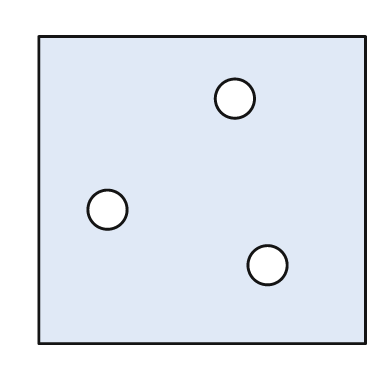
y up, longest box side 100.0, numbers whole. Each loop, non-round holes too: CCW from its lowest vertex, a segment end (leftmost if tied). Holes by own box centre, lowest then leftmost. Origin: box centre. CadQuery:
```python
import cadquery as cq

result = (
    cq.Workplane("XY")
    .moveTo(-50.0, -47.0)
    .lineTo(50.0, -47.0)
    .lineTo(50.0, 47.0)
    .lineTo(-50.0, 47.0)
    .close()
    .moveTo(20.0, -23.0)
    .circle(6.0)
    .moveTo(-29.0, -6.0)
    .circle(6.0)
    .moveTo(10.0, 28.0)
    .circle(6.0)
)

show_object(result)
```